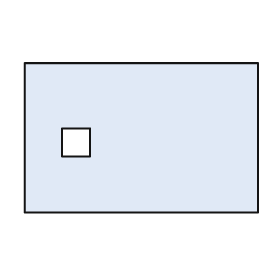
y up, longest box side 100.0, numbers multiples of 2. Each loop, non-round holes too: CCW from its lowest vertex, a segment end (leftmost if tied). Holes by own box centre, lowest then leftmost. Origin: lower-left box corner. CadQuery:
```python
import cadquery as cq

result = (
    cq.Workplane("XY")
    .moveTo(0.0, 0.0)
    .lineTo(100.0, 0.0)
    .lineTo(100.0, 64.0)
    .lineTo(0.0, 64.0)
    .close()
    .moveTo(16.0, 24.0)
    .lineTo(28.0, 24.0)
    .lineTo(28.0, 36.0)
    .lineTo(16.0, 36.0)
    .close()
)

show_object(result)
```